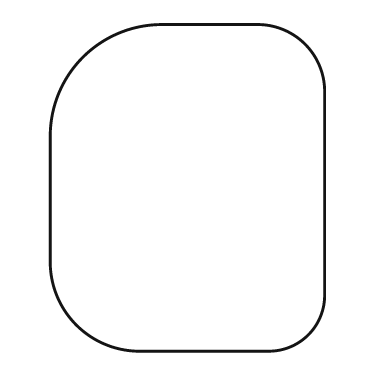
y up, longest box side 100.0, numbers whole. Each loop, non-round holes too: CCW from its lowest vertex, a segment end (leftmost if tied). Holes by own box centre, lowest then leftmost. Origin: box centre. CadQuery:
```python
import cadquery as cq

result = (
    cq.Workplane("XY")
    .moveTo(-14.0, -50.0)
    .lineTo(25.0, -50.0)
    .threePointArc((37.0, -45.0), (42.0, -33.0))
    .lineTo(42.0, 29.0)
    .threePointArc((36.0, 44.0), (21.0, 50.0))
    .lineTo(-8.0, 50.0)
    .threePointArc((-32.0, 40.0), (-42.0, 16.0))
    .lineTo(-42.0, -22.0)
    .threePointArc((-34.0, -42.0), (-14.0, -50.0))
    .close()
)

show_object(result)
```